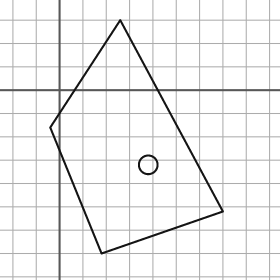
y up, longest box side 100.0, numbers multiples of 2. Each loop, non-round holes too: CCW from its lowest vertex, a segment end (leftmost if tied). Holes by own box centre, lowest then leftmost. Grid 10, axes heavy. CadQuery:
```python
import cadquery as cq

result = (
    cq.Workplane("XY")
    .moveTo(18.0, -70.0)
    .lineTo(70.0, -52.0)
    .lineTo(26.0, 30.0)
    .lineTo(-4.0, -16.0)
    .close()
    .moveTo(38.0, -32.0)
    .circle(4.0)
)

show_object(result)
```